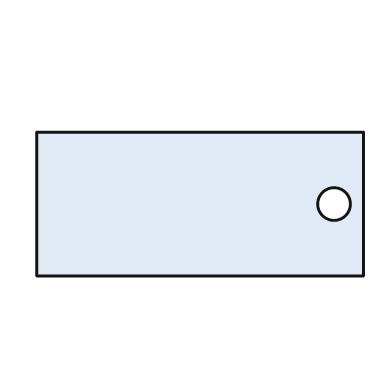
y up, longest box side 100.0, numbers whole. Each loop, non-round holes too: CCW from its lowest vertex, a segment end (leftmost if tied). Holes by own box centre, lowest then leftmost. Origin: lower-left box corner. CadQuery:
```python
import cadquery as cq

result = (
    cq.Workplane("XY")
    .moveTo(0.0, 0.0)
    .lineTo(100.0, 0.0)
    .lineTo(100.0, 44.0)
    .lineTo(0.0, 44.0)
    .close()
    .moveTo(91.0, 22.0)
    .circle(5.0)
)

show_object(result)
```